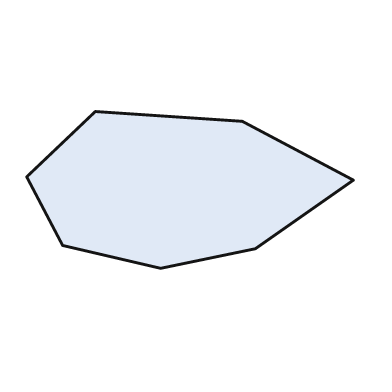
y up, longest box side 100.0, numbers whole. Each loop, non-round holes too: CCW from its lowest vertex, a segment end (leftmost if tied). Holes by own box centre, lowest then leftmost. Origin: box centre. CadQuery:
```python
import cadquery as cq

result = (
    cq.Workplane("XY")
    .moveTo(-9.0, -24.0)
    .lineTo(20.0, -18.0)
    .lineTo(50.0, 3.0)
    .lineTo(16.0, 21.0)
    .lineTo(-29.0, 24.0)
    .lineTo(-50.0, 4.0)
    .lineTo(-39.0, -17.0)
    .close()
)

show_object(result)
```